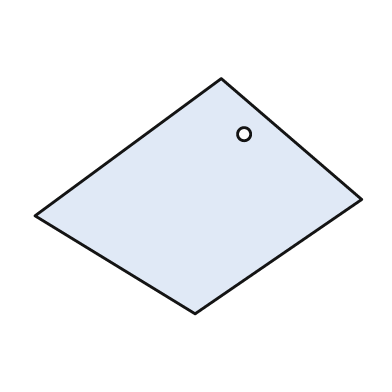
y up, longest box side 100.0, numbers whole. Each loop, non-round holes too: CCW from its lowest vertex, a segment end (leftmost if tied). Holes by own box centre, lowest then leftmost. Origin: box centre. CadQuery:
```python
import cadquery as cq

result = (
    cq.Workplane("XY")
    .moveTo(-1.0, -36.0)
    .lineTo(50.0, -1.0)
    .lineTo(7.0, 36.0)
    .lineTo(-50.0, -6.0)
    .close()
    .moveTo(14.0, 19.0)
    .circle(2.0)
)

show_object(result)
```